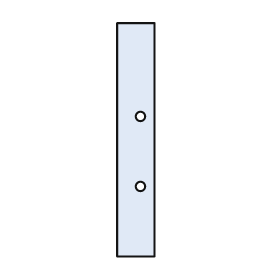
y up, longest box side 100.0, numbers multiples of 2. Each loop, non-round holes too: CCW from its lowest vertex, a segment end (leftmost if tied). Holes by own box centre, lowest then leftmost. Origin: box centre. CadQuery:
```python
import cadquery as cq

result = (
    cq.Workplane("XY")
    .moveTo(-8.0, -50.0)
    .lineTo(8.0, -50.0)
    .lineTo(8.0, 50.0)
    .lineTo(-8.0, 50.0)
    .close()
    .moveTo(2.0, -20.0)
    .circle(2.0)
    .moveTo(2.0, 10.0)
    .circle(2.0)
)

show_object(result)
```